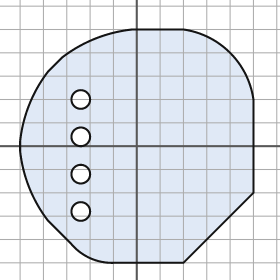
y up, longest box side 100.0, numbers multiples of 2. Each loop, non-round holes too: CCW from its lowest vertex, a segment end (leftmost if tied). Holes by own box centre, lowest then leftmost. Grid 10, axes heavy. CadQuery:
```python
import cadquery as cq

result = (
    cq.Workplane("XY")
    .moveTo(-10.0, -50.0)
    .lineTo(20.0, -50.0)
    .lineTo(50.0, -20.0)
    .lineTo(50.0, 20.0)
    .threePointArc((40.0, 40.0), (20.0, 50.0))
    .lineTo(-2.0, 50.0)
    .threePointArc((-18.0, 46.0), (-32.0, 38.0))
    .lineTo(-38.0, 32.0)
    .threePointArc((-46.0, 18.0), (-50.0, 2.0))
    .lineTo(-50.0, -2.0)
    .threePointArc((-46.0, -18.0), (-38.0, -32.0))
    .lineTo(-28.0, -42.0)
    .threePointArc((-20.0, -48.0), (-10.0, -50.0))
    .close()
    .moveTo(-24.0, -28.0)
    .circle(4.0)
    .moveTo(-24.0, -12.0)
    .circle(4.0)
    .moveTo(-24.0, 4.0)
    .circle(4.0)
    .moveTo(-24.0, 20.0)
    .circle(4.0)
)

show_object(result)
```